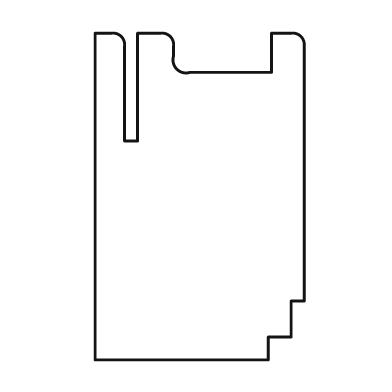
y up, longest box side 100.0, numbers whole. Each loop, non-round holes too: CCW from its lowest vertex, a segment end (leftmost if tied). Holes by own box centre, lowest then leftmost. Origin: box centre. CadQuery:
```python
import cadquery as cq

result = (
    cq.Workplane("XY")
    .moveTo(-32.0, -50.0)
    .lineTo(21.0, -50.0)
    .lineTo(21.0, -43.0)
    .lineTo(28.0, -43.0)
    .lineTo(28.0, -32.0)
    .lineTo(32.0, -32.0)
    .lineTo(32.0, 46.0)
    .threePointArc((31.0, 49.0), (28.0, 50.0))
    .lineTo(22.0, 50.0)
    .lineTo(22.0, 38.0)
    .lineTo(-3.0, 38.0)
    .threePointArc((-7.0, 39.0), (-8.0, 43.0))
    .lineTo(-8.0, 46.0)
    .threePointArc((-9.0, 49.0), (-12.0, 50.0))
    .lineTo(-19.0, 50.0)
    .lineTo(-19.0, 17.0)
    .lineTo(-23.0, 17.0)
    .lineTo(-23.0, 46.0)
    .threePointArc((-24.0, 49.0), (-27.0, 50.0))
    .lineTo(-32.0, 50.0)
    .close()
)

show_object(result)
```